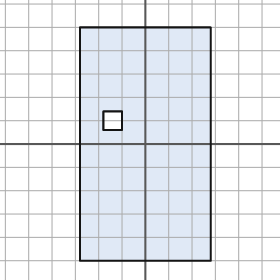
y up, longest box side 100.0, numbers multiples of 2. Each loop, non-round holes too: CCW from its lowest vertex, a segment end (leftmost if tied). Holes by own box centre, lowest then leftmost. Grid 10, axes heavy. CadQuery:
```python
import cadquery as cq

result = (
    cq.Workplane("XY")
    .moveTo(-28.0, -50.0)
    .lineTo(28.0, -50.0)
    .lineTo(28.0, 50.0)
    .lineTo(-28.0, 50.0)
    .close()
    .moveTo(-18.0, 6.0)
    .lineTo(-10.0, 6.0)
    .lineTo(-10.0, 14.0)
    .lineTo(-18.0, 14.0)
    .close()
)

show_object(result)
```